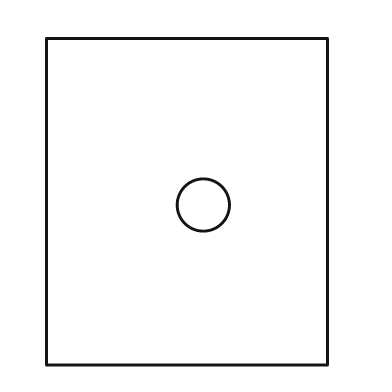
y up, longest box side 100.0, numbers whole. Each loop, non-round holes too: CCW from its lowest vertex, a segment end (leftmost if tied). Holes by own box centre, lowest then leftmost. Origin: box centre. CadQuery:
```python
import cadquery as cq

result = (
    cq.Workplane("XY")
    .moveTo(-43.0, -50.0)
    .lineTo(43.0, -50.0)
    .lineTo(43.0, 50.0)
    .lineTo(-43.0, 50.0)
    .close()
    .moveTo(5.0, -1.0)
    .circle(8.0)
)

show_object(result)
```